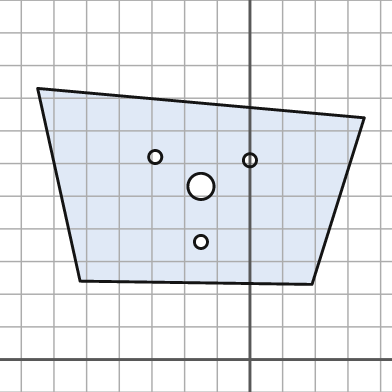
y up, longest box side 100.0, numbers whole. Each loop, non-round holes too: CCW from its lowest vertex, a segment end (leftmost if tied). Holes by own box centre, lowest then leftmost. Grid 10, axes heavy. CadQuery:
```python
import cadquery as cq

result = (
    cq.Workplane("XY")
    .moveTo(19.0, 23.0)
    .lineTo(35.0, 74.0)
    .lineTo(-65.0, 83.0)
    .lineTo(-52.0, 24.0)
    .close()
    .moveTo(-15.0, 36.0)
    .circle(2.0)
    .moveTo(-15.0, 53.0)
    .circle(4.0)
    .moveTo(0.0, 61.0)
    .circle(2.0)
    .moveTo(-29.0, 62.0)
    .circle(2.0)
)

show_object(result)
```